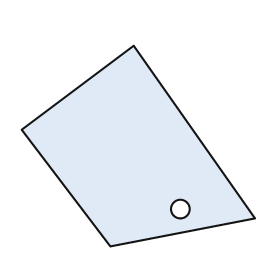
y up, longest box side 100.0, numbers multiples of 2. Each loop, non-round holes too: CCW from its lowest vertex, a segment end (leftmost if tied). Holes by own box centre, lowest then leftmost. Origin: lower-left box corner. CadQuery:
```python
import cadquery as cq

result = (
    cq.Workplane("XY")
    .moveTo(38.0, 0.0)
    .lineTo(100.0, 12.0)
    .lineTo(48.0, 86.0)
    .lineTo(0.0, 50.0)
    .close()
    .moveTo(68.0, 16.0)
    .circle(4.0)
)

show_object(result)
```